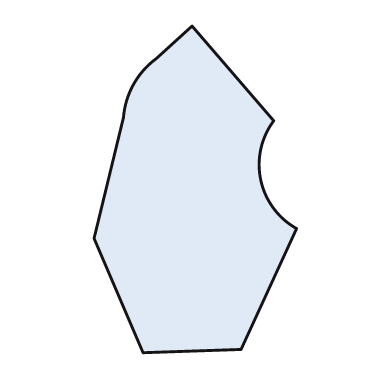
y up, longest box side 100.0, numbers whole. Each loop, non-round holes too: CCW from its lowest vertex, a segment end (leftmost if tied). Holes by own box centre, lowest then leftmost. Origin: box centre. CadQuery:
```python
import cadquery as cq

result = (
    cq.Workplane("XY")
    .moveTo(-16.0, -50.0)
    .lineTo(14.0, -49.0)
    .lineTo(31.0, -12.0)
    .threePointArc((20.0, 3.0), (24.0, 21.0))
    .lineTo(-1.0, 50.0)
    .lineTo(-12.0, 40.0)
    .threePointArc((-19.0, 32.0), (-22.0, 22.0))
    .lineTo(-31.0, -15.0)
    .close()
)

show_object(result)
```